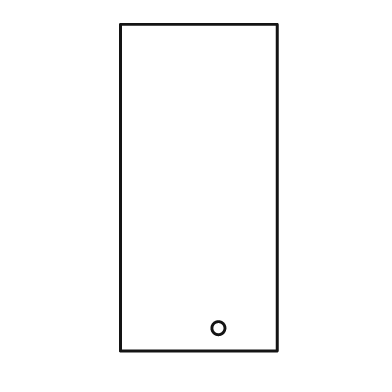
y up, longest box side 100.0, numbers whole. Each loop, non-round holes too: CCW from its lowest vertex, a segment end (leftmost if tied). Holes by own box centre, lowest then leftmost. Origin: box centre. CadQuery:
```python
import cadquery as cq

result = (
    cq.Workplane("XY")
    .moveTo(-24.0, -50.0)
    .lineTo(24.0, -50.0)
    .lineTo(24.0, 50.0)
    .lineTo(-24.0, 50.0)
    .close()
    .moveTo(6.0, -43.0)
    .circle(2.0)
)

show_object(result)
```